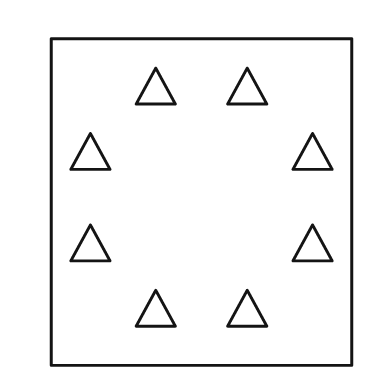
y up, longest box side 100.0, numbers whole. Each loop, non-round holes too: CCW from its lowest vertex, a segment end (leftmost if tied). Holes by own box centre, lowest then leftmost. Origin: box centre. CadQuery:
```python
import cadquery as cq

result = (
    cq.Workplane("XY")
    .moveTo(-46.0, -50.0)
    .lineTo(46.0, -50.0)
    .lineTo(46.0, 50.0)
    .lineTo(-46.0, 50.0)
    .close()
    .moveTo(-20.0, -38.0)
    .lineTo(-8.0, -38.0)
    .lineTo(-14.0, -27.0)
    .close()
    .moveTo(8.0, -38.0)
    .lineTo(20.0, -38.0)
    .lineTo(14.0, -27.0)
    .close()
    .moveTo(-40.0, -18.0)
    .lineTo(-28.0, -18.0)
    .lineTo(-34.0, -7.0)
    .close()
    .moveTo(28.0, -18.0)
    .lineTo(40.0, -18.0)
    .lineTo(34.0, -7.0)
    .close()
    .moveTo(-40.0, 10.0)
    .lineTo(-28.0, 10.0)
    .lineTo(-34.0, 21.0)
    .close()
    .moveTo(28.0, 10.0)
    .lineTo(40.0, 10.0)
    .lineTo(34.0, 21.0)
    .close()
    .moveTo(-20.0, 30.0)
    .lineTo(-8.0, 30.0)
    .lineTo(-14.0, 41.0)
    .close()
    .moveTo(8.0, 30.0)
    .lineTo(20.0, 30.0)
    .lineTo(14.0, 41.0)
    .close()
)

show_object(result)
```